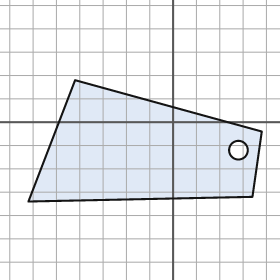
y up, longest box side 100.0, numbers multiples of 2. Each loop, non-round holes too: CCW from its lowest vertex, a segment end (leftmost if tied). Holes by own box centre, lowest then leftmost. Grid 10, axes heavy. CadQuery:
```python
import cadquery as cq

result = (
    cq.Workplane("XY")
    .moveTo(-62.0, -34.0)
    .lineTo(34.0, -32.0)
    .lineTo(38.0, -4.0)
    .lineTo(-42.0, 18.0)
    .close()
    .moveTo(28.0, -12.0)
    .circle(4.0)
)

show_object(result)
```